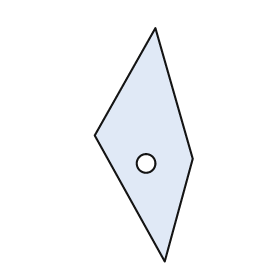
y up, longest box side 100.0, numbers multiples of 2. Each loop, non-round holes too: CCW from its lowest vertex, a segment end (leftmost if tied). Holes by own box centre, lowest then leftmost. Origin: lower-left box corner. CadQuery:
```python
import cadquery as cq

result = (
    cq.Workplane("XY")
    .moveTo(30.0, 0.0)
    .lineTo(42.0, 44.0)
    .lineTo(26.0, 100.0)
    .lineTo(0.0, 54.0)
    .close()
    .moveTo(22.0, 42.0)
    .circle(4.0)
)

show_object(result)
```